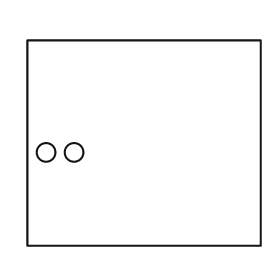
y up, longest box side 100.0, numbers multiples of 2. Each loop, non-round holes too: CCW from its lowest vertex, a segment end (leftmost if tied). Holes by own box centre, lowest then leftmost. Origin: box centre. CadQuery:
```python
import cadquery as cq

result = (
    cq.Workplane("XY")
    .moveTo(-50.0, -44.0)
    .lineTo(50.0, -44.0)
    .lineTo(50.0, 44.0)
    .lineTo(-50.0, 44.0)
    .close()
    .moveTo(-42.0, -4.0)
    .circle(4.0)
    .moveTo(-30.0, -4.0)
    .circle(4.0)
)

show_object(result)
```